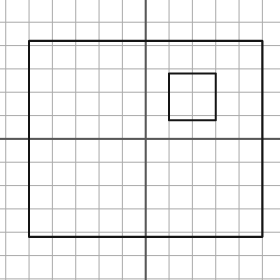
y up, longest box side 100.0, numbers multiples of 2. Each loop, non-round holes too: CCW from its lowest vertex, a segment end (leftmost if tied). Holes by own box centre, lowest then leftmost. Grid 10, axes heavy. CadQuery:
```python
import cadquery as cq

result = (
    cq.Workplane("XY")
    .moveTo(-50.0, -42.0)
    .lineTo(50.0, -42.0)
    .lineTo(50.0, 42.0)
    .lineTo(-50.0, 42.0)
    .close()
    .moveTo(10.0, 8.0)
    .lineTo(30.0, 8.0)
    .lineTo(30.0, 28.0)
    .lineTo(10.0, 28.0)
    .close()
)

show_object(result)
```